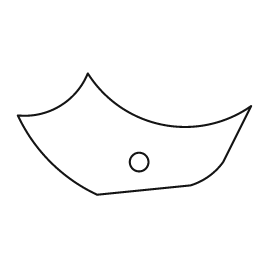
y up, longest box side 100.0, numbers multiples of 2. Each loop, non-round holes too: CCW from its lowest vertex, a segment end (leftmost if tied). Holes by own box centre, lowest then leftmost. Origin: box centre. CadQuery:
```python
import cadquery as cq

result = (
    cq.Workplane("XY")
    .moveTo(-16.0, -26.0)
    .lineTo(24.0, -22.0)
    .threePointArc((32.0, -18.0), (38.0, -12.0))
    .lineTo(50.0, 12.0)
    .threePointArc((12.0, 4.0), (-20.0, 26.0))
    .threePointArc((-32.0, 12.0), (-50.0, 8.0))
    .threePointArc((-36.0, -12.0), (-16.0, -26.0))
    .close()
    .moveTo(2.0, -12.0)
    .circle(4.0)
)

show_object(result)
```